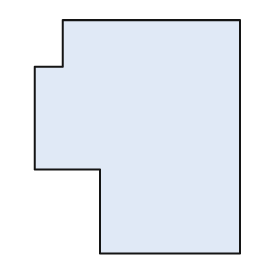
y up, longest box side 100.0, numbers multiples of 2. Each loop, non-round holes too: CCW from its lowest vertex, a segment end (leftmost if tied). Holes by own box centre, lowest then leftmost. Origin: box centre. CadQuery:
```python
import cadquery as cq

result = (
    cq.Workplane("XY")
    .moveTo(-16.0, -50.0)
    .lineTo(44.0, -50.0)
    .lineTo(44.0, 50.0)
    .lineTo(-32.0, 50.0)
    .lineTo(-32.0, 30.0)
    .lineTo(-44.0, 30.0)
    .lineTo(-44.0, -14.0)
    .lineTo(-16.0, -14.0)
    .close()
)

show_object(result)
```